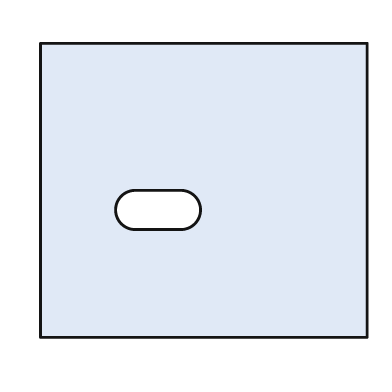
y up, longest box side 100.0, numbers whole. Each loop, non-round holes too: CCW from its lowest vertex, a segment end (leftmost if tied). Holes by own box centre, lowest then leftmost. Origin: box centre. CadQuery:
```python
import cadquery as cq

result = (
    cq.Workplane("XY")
    .moveTo(-50.0, -45.0)
    .lineTo(50.0, -45.0)
    .lineTo(50.0, 45.0)
    .lineTo(-50.0, 45.0)
    .close()
    .moveTo(-21.0, -12.0)
    .lineTo(-7.0, -12.0)
    .threePointArc((-1.0, -6.0), (-7.0, 0.0))
    .lineTo(-21.0, 0.0)
    .threePointArc((-27.0, -6.0), (-21.0, -12.0))
    .close()
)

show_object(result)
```